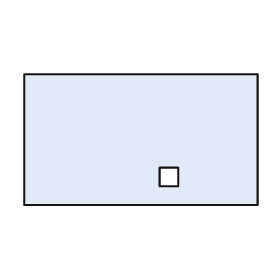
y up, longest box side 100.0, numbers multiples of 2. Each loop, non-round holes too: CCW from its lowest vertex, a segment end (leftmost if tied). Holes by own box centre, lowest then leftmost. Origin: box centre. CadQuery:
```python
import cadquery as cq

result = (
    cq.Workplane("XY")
    .moveTo(-50.0, -28.0)
    .lineTo(50.0, -28.0)
    .lineTo(50.0, 28.0)
    .lineTo(-50.0, 28.0)
    .close()
    .moveTo(8.0, -20.0)
    .lineTo(16.0, -20.0)
    .lineTo(16.0, -12.0)
    .lineTo(8.0, -12.0)
    .close()
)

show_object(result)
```